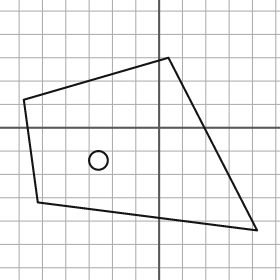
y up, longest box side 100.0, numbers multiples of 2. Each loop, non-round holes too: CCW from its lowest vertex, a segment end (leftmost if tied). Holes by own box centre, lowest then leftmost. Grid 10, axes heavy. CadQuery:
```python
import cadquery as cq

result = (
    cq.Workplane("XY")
    .moveTo(42.0, -44.0)
    .lineTo(4.0, 30.0)
    .lineTo(-58.0, 12.0)
    .lineTo(-52.0, -32.0)
    .close()
    .moveTo(-26.0, -14.0)
    .circle(4.0)
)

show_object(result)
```